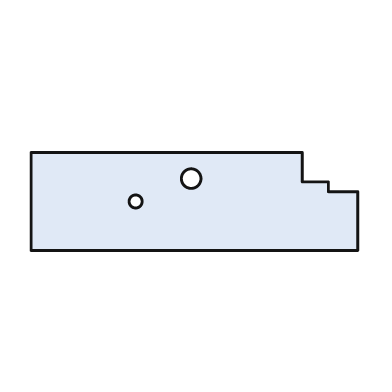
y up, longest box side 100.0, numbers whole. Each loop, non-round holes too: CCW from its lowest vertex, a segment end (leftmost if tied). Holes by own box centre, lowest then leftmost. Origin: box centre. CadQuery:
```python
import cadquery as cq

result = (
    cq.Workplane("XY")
    .moveTo(-50.0, -15.0)
    .lineTo(50.0, -15.0)
    .lineTo(50.0, 3.0)
    .lineTo(41.0, 3.0)
    .lineTo(41.0, 6.0)
    .lineTo(33.0, 6.0)
    .lineTo(33.0, 15.0)
    .lineTo(-50.0, 15.0)
    .close()
    .moveTo(-18.0, 0.0)
    .circle(2.0)
    .moveTo(-1.0, 7.0)
    .circle(3.0)
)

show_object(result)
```